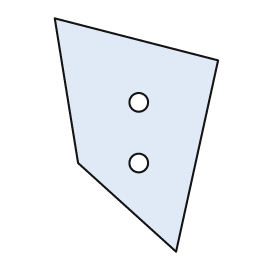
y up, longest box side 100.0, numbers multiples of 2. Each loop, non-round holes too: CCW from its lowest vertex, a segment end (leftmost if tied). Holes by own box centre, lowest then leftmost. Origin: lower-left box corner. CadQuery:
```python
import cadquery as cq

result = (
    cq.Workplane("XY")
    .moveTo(52.0, 0.0)
    .lineTo(70.0, 82.0)
    .lineTo(0.0, 100.0)
    .lineTo(10.0, 38.0)
    .close()
    .moveTo(36.0, 38.0)
    .circle(4.0)
    .moveTo(36.0, 64.0)
    .circle(4.0)
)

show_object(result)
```